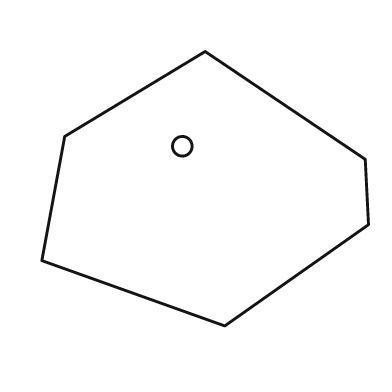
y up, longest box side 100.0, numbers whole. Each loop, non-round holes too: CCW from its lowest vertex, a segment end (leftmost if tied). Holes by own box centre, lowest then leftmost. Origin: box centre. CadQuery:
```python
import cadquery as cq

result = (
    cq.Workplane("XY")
    .moveTo(6.0, -42.0)
    .lineTo(50.0, -11.0)
    .lineTo(49.0, 9.0)
    .lineTo(0.0, 42.0)
    .lineTo(-43.0, 16.0)
    .lineTo(-50.0, -22.0)
    .close()
    .moveTo(-7.0, 13.0)
    .circle(3.0)
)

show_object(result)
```